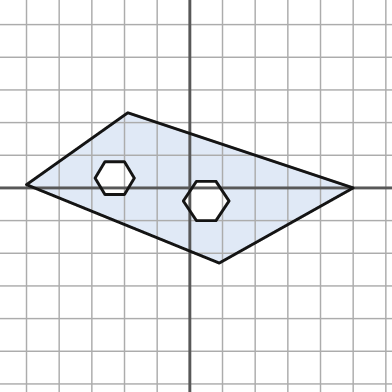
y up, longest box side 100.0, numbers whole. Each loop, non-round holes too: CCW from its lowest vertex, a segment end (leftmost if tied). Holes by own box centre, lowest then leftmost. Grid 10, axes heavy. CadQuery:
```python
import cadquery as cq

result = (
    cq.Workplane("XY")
    .moveTo(9.0, -23.0)
    .lineTo(50.0, 0.0)
    .lineTo(-19.0, 23.0)
    .lineTo(-50.0, 1.0)
    .close()
    .moveTo(2.0, -10.0)
    .lineTo(8.0, -10.0)
    .lineTo(12.0, -4.0)
    .lineTo(8.0, 2.0)
    .lineTo(2.0, 2.0)
    .lineTo(-2.0, -4.0)
    .close()
    .moveTo(-26.0, -2.0)
    .lineTo(-20.0, -2.0)
    .lineTo(-17.0, 3.0)
    .lineTo(-20.0, 8.0)
    .lineTo(-26.0, 8.0)
    .lineTo(-29.0, 3.0)
    .close()
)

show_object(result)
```